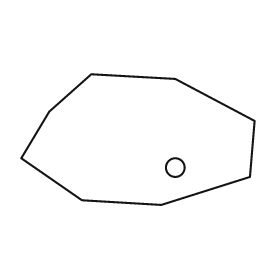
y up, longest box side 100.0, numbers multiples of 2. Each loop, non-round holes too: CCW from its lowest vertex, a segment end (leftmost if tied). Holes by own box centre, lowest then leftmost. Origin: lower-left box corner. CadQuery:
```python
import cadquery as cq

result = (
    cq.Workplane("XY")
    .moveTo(60.0, 0.0)
    .lineTo(98.0, 12.0)
    .lineTo(100.0, 36.0)
    .lineTo(66.0, 54.0)
    .lineTo(30.0, 56.0)
    .lineTo(12.0, 40.0)
    .lineTo(0.0, 20.0)
    .lineTo(26.0, 2.0)
    .close()
    .moveTo(66.0, 16.0)
    .circle(4.0)
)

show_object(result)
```